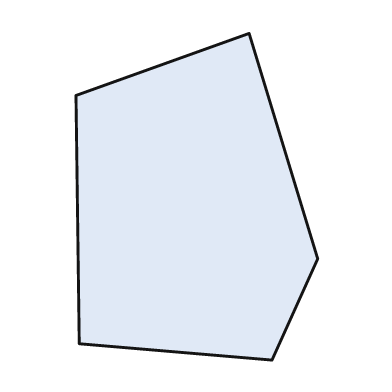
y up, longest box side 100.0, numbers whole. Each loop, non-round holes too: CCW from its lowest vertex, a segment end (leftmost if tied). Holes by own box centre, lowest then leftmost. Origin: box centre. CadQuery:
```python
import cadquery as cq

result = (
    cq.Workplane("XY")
    .moveTo(23.0, -50.0)
    .lineTo(37.0, -19.0)
    .lineTo(16.0, 50.0)
    .lineTo(-37.0, 31.0)
    .lineTo(-36.0, -45.0)
    .close()
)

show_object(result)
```